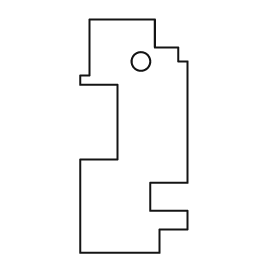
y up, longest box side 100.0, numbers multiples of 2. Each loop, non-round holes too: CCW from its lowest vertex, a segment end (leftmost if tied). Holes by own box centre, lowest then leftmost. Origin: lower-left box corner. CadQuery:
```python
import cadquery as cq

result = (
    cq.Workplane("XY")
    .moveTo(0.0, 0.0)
    .lineTo(34.0, 0.0)
    .lineTo(34.0, 10.0)
    .lineTo(46.0, 10.0)
    .lineTo(46.0, 18.0)
    .lineTo(30.0, 18.0)
    .lineTo(30.0, 30.0)
    .lineTo(46.0, 30.0)
    .lineTo(46.0, 82.0)
    .lineTo(42.0, 82.0)
    .lineTo(42.0, 88.0)
    .lineTo(32.0, 88.0)
    .lineTo(32.0, 100.0)
    .lineTo(4.0, 100.0)
    .lineTo(4.0, 76.0)
    .lineTo(0.0, 76.0)
    .lineTo(0.0, 72.0)
    .lineTo(16.0, 72.0)
    .lineTo(16.0, 40.0)
    .lineTo(0.0, 40.0)
    .close()
    .moveTo(26.0, 82.0)
    .circle(4.0)
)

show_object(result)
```